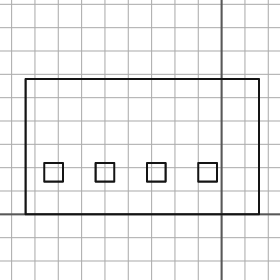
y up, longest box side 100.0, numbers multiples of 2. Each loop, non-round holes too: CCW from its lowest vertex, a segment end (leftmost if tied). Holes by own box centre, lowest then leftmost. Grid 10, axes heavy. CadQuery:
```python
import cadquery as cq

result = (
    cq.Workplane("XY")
    .moveTo(-84.0, 0.0)
    .lineTo(16.0, 0.0)
    .lineTo(16.0, 58.0)
    .lineTo(-84.0, 58.0)
    .close()
    .moveTo(-76.0, 14.0)
    .lineTo(-68.0, 14.0)
    .lineTo(-68.0, 22.0)
    .lineTo(-76.0, 22.0)
    .close()
    .moveTo(-54.0, 14.0)
    .lineTo(-46.0, 14.0)
    .lineTo(-46.0, 22.0)
    .lineTo(-54.0, 22.0)
    .close()
    .moveTo(-32.0, 14.0)
    .lineTo(-24.0, 14.0)
    .lineTo(-24.0, 22.0)
    .lineTo(-32.0, 22.0)
    .close()
    .moveTo(-10.0, 14.0)
    .lineTo(-2.0, 14.0)
    .lineTo(-2.0, 22.0)
    .lineTo(-10.0, 22.0)
    .close()
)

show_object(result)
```